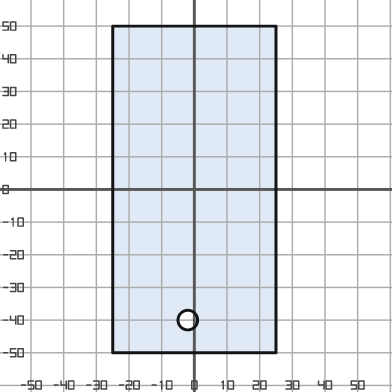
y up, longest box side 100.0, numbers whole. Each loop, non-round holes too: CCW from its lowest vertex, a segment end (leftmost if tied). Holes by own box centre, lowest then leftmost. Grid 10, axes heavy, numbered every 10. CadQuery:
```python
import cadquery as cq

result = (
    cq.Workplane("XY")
    .moveTo(-25.0, -50.0)
    .lineTo(25.0, -50.0)
    .lineTo(25.0, 50.0)
    .lineTo(-25.0, 50.0)
    .close()
    .moveTo(-2.0, -40.0)
    .circle(3.0)
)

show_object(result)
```